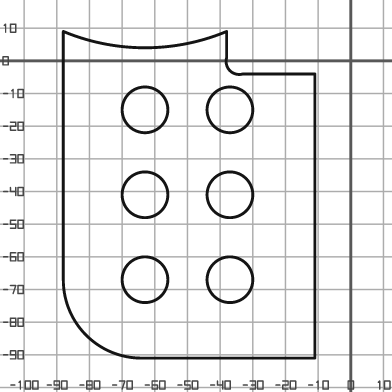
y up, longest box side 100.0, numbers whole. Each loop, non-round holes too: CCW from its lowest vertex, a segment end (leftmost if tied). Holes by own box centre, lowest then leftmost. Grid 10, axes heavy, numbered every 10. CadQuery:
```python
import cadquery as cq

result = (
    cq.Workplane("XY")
    .moveTo(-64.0, -91.0)
    .lineTo(-11.0, -91.0)
    .lineTo(-11.0, -4.0)
    .lineTo(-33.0, -4.0)
    .threePointArc((-37.0, -3.0), (-38.0, 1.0))
    .lineTo(-38.0, 9.0)
    .threePointArc((-63.0, 4.0), (-88.0, 9.0))
    .lineTo(-88.0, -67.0)
    .threePointArc((-81.0, -84.0), (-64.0, -91.0))
    .close()
    .moveTo(-63.0, -67.0)
    .circle(7.0)
    .moveTo(-37.0, -67.0)
    .circle(7.0)
    .moveTo(-63.0, -41.0)
    .circle(7.0)
    .moveTo(-37.0, -41.0)
    .circle(7.0)
    .moveTo(-63.0, -15.0)
    .circle(7.0)
    .moveTo(-37.0, -15.0)
    .circle(7.0)
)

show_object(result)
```